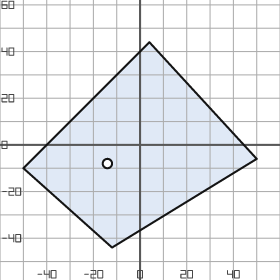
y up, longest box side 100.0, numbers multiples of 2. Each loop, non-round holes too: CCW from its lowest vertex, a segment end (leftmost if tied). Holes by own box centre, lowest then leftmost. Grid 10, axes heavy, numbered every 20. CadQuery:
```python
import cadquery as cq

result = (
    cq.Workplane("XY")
    .moveTo(-12.0, -44.0)
    .lineTo(50.0, -6.0)
    .lineTo(4.0, 44.0)
    .lineTo(-50.0, -10.0)
    .close()
    .moveTo(-14.0, -8.0)
    .circle(2.0)
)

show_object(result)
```